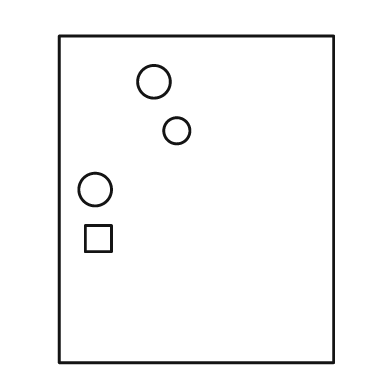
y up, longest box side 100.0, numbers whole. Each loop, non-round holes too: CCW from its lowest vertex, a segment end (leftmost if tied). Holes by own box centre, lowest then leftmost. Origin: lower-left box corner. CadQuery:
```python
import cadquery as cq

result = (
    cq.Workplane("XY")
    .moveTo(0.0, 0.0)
    .lineTo(84.0, 0.0)
    .lineTo(84.0, 100.0)
    .lineTo(0.0, 100.0)
    .close()
    .moveTo(8.0, 34.0)
    .lineTo(16.0, 34.0)
    .lineTo(16.0, 42.0)
    .lineTo(8.0, 42.0)
    .close()
    .moveTo(11.0, 53.0)
    .circle(5.0)
    .moveTo(36.0, 71.0)
    .circle(4.0)
    .moveTo(29.0, 86.0)
    .circle(5.0)
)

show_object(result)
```